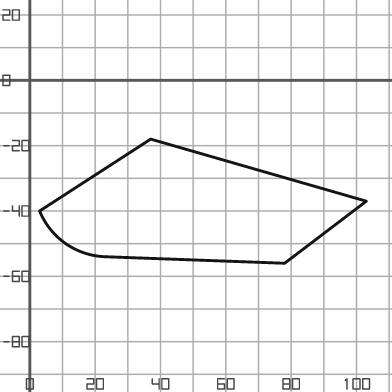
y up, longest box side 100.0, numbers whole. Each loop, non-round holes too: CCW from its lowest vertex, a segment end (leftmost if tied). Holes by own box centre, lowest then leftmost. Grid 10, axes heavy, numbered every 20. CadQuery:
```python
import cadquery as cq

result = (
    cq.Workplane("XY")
    .moveTo(78.0, -56.0)
    .lineTo(103.0, -37.0)
    .lineTo(37.0, -18.0)
    .lineTo(3.0, -40.0)
    .threePointArc((11.0, -50.0), (23.0, -54.0))
    .close()
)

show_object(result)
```